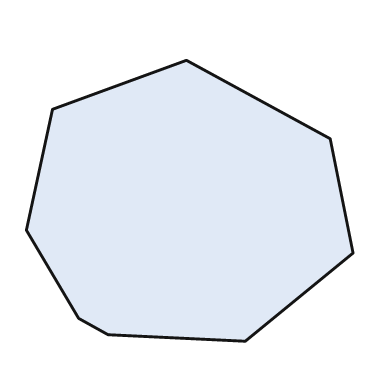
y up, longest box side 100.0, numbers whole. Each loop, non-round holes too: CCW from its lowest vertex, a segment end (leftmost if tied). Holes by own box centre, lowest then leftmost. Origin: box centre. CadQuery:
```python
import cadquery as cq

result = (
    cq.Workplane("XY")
    .moveTo(17.0, -43.0)
    .lineTo(50.0, -16.0)
    .lineTo(43.0, 19.0)
    .lineTo(-1.0, 43.0)
    .lineTo(-42.0, 28.0)
    .lineTo(-50.0, -9.0)
    .lineTo(-34.0, -36.0)
    .lineTo(-25.0, -41.0)
    .close()
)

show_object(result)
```